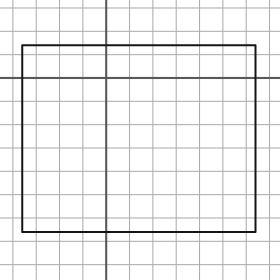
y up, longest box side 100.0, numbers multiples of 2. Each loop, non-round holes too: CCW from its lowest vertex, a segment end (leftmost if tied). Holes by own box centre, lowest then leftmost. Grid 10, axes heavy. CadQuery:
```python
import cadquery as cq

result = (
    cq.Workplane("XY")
    .moveTo(-36.0, -66.0)
    .lineTo(64.0, -66.0)
    .lineTo(64.0, 14.0)
    .lineTo(-36.0, 14.0)
    .close()
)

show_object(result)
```